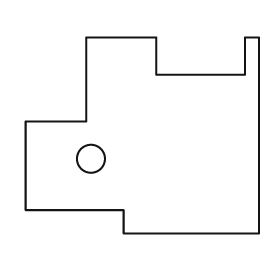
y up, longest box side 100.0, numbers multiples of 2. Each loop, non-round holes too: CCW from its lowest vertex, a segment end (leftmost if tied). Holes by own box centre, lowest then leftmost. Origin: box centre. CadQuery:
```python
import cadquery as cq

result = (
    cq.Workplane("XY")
    .moveTo(-8.0, -42.0)
    .lineTo(50.0, -42.0)
    .lineTo(50.0, 42.0)
    .lineTo(44.0, 42.0)
    .lineTo(44.0, 26.0)
    .lineTo(6.0, 26.0)
    .lineTo(6.0, 42.0)
    .lineTo(-24.0, 42.0)
    .lineTo(-24.0, 6.0)
    .lineTo(-50.0, 6.0)
    .lineTo(-50.0, -32.0)
    .lineTo(-8.0, -32.0)
    .close()
    .moveTo(-22.0, -10.0)
    .circle(6.0)
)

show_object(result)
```